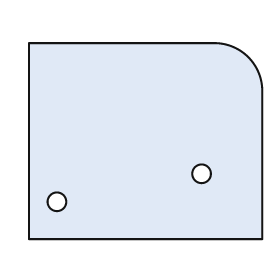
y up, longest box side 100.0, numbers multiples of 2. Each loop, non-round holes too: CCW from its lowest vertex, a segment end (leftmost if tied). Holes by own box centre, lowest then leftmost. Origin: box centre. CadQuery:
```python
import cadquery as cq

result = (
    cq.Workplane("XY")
    .moveTo(-50.0, -42.0)
    .lineTo(50.0, -42.0)
    .lineTo(50.0, 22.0)
    .threePointArc((44.0, 36.0), (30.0, 42.0))
    .lineTo(-50.0, 42.0)
    .close()
    .moveTo(-38.0, -26.0)
    .circle(4.0)
    .moveTo(24.0, -14.0)
    .circle(4.0)
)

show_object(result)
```